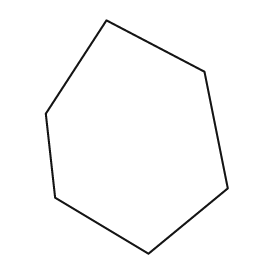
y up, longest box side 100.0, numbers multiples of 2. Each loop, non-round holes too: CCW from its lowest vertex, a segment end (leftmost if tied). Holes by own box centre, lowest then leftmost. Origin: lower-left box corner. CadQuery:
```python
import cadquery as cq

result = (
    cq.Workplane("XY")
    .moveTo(44.0, 0.0)
    .lineTo(78.0, 28.0)
    .lineTo(68.0, 78.0)
    .lineTo(26.0, 100.0)
    .lineTo(0.0, 60.0)
    .lineTo(4.0, 24.0)
    .close()
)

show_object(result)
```